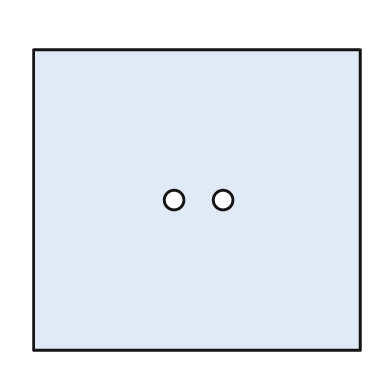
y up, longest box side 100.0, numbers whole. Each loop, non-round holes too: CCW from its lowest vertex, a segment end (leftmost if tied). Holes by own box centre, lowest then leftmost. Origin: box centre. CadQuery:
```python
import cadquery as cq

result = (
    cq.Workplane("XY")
    .moveTo(-50.0, -46.0)
    .lineTo(50.0, -46.0)
    .lineTo(50.0, 46.0)
    .lineTo(-50.0, 46.0)
    .close()
    .moveTo(-7.0, 0.0)
    .circle(3.0)
    .moveTo(8.0, 0.0)
    .circle(3.0)
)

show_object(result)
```